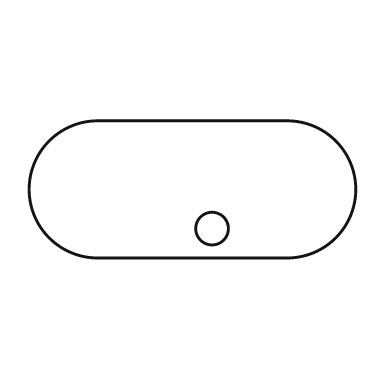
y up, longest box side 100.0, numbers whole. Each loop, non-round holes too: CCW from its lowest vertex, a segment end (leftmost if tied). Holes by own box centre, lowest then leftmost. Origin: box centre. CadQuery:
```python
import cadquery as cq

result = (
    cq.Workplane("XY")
    .moveTo(-29.0, -21.0)
    .lineTo(29.0, -21.0)
    .threePointArc((50.0, 0.0), (29.0, 21.0))
    .lineTo(-29.0, 21.0)
    .threePointArc((-50.0, 0.0), (-29.0, -21.0))
    .close()
    .moveTo(6.0, -12.0)
    .circle(5.0)
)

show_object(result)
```